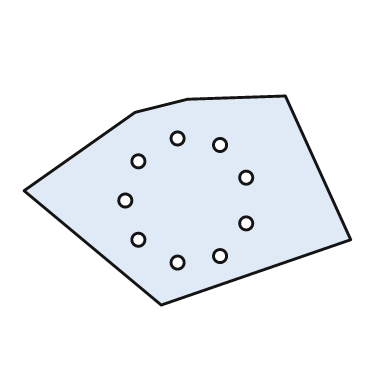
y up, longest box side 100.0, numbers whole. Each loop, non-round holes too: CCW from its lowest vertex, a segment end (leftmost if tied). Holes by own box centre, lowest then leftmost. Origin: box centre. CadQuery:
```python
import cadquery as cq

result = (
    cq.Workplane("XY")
    .moveTo(-8.0, -32.0)
    .lineTo(50.0, -12.0)
    .lineTo(30.0, 32.0)
    .lineTo(0.0, 31.0)
    .lineTo(-16.0, 27.0)
    .lineTo(-50.0, 3.0)
    .close()
    .moveTo(-3.0, -19.0)
    .circle(2.0)
    .moveTo(10.0, -17.0)
    .circle(2.0)
    .moveTo(-15.0, -12.0)
    .circle(2.0)
    .moveTo(18.0, -7.0)
    .circle(2.0)
    .moveTo(-19.0, 0.0)
    .circle(2.0)
    .moveTo(18.0, 7.0)
    .circle(2.0)
    .moveTo(-15.0, 12.0)
    .circle(2.0)
    .moveTo(10.0, 17.0)
    .circle(2.0)
    .moveTo(-3.0, 19.0)
    .circle(2.0)
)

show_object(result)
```